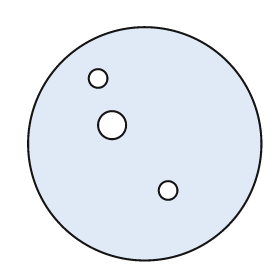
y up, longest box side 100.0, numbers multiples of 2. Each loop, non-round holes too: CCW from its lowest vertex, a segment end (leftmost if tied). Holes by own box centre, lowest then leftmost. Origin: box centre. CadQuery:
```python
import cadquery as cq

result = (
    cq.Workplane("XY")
    .moveTo(0.0, 0.0)
    .circle(50.0)
    .moveTo(10.0, -20.0)
    .circle(4.0)
    .moveTo(-14.0, 8.0)
    .circle(6.0)
    .moveTo(-20.0, 28.0)
    .circle(4.0)
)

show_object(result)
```